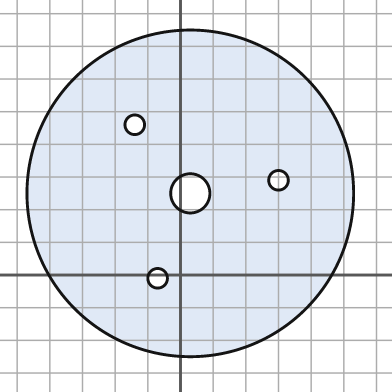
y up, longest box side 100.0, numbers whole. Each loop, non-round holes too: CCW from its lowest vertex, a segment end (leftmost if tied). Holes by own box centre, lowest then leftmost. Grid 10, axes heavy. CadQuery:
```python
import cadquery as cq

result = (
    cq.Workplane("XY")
    .moveTo(3.0, 25.0)
    .circle(50.0)
    .moveTo(-7.0, -1.0)
    .circle(3.0)
    .moveTo(3.0, 25.0)
    .circle(6.0)
    .moveTo(30.0, 29.0)
    .circle(3.0)
    .moveTo(-14.0, 46.0)
    .circle(3.0)
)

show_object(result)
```